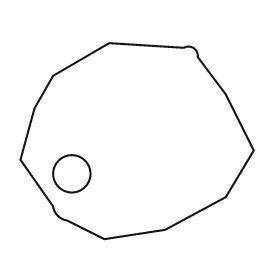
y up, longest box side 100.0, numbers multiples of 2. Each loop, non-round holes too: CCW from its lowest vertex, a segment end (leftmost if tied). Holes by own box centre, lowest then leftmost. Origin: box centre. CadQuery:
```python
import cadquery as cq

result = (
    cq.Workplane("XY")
    .moveTo(-14.0, -42.0)
    .lineTo(12.0, -38.0)
    .lineTo(38.0, -24.0)
    .lineTo(50.0, -4.0)
    .lineTo(38.0, 20.0)
    .lineTo(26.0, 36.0)
    .threePointArc((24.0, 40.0), (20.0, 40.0))
    .lineTo(-12.0, 42.0)
    .lineTo(-36.0, 28.0)
    .lineTo(-44.0, 14.0)
    .lineTo(-50.0, -8.0)
    .lineTo(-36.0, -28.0)
    .threePointArc((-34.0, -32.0), (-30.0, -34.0))
    .close()
    .moveTo(-28.0, -14.0)
    .circle(8.0)
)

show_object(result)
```